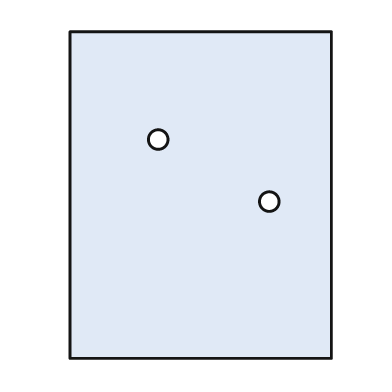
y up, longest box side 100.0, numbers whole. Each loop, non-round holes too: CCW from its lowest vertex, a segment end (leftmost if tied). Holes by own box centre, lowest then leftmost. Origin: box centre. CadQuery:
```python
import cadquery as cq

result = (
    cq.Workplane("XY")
    .moveTo(-40.0, -50.0)
    .lineTo(40.0, -50.0)
    .lineTo(40.0, 50.0)
    .lineTo(-40.0, 50.0)
    .close()
    .moveTo(21.0, -2.0)
    .circle(3.0)
    .moveTo(-13.0, 17.0)
    .circle(3.0)
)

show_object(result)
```